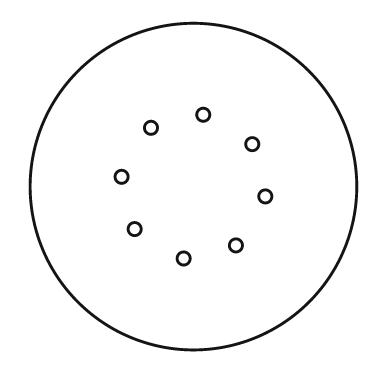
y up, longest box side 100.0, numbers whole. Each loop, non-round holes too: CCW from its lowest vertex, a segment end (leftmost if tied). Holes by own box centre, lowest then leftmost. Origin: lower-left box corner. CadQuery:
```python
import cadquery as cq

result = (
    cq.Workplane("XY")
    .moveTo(50.0, 50.0)
    .circle(50.0)
    .moveTo(47.0, 28.0)
    .circle(2.0)
    .moveTo(63.0, 32.0)
    .circle(2.0)
    .moveTo(32.0, 37.0)
    .circle(2.0)
    .moveTo(72.0, 47.0)
    .circle(2.0)
    .moveTo(28.0, 53.0)
    .circle(2.0)
    .moveTo(68.0, 63.0)
    .circle(2.0)
    .moveTo(37.0, 68.0)
    .circle(2.0)
    .moveTo(53.0, 72.0)
    .circle(2.0)
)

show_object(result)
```